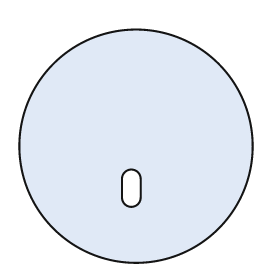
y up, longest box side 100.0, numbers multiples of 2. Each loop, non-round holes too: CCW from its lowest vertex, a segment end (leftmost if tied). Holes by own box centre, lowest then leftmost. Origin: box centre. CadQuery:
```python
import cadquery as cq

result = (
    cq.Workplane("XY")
    .moveTo(0.0, 0.0)
    .circle(50.0)
    .moveTo(-6.0, -22.0)
    .threePointArc((-2.0, -26.0), (2.0, -22.0))
    .lineTo(2.0, -14.0)
    .threePointArc((-2.0, -10.0), (-6.0, -14.0))
    .close()
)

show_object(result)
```